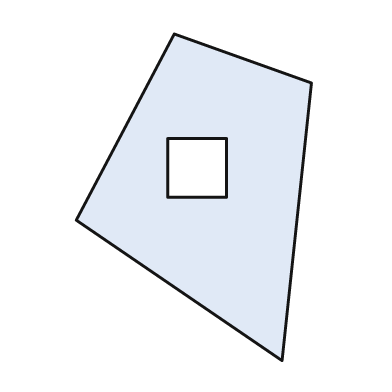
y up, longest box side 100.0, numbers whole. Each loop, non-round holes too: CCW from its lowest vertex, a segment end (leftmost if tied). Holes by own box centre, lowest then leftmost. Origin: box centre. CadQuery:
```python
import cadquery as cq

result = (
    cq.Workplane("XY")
    .moveTo(27.0, -50.0)
    .lineTo(36.0, 35.0)
    .lineTo(-6.0, 50.0)
    .lineTo(-36.0, -7.0)
    .close()
    .moveTo(-8.0, 0.0)
    .lineTo(10.0, 0.0)
    .lineTo(10.0, 18.0)
    .lineTo(-8.0, 18.0)
    .close()
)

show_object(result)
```